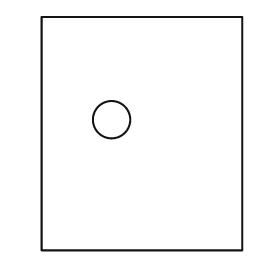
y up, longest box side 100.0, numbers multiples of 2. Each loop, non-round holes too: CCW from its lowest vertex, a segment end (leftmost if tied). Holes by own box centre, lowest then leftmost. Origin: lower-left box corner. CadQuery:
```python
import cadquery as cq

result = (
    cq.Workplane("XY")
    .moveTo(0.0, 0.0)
    .lineTo(86.0, 0.0)
    .lineTo(86.0, 100.0)
    .lineTo(0.0, 100.0)
    .close()
    .moveTo(30.0, 56.0)
    .circle(8.0)
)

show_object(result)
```